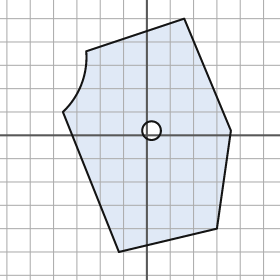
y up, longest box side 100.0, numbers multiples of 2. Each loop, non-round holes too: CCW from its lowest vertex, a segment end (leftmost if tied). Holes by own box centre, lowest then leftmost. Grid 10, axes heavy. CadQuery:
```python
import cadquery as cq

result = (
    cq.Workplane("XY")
    .moveTo(-12.0, -50.0)
    .lineTo(30.0, -40.0)
    .lineTo(36.0, 2.0)
    .lineTo(16.0, 50.0)
    .lineTo(-26.0, 36.0)
    .threePointArc((-28.0, 22.0), (-36.0, 10.0))
    .close()
    .moveTo(2.0, 2.0)
    .circle(4.0)
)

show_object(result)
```